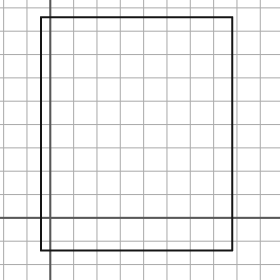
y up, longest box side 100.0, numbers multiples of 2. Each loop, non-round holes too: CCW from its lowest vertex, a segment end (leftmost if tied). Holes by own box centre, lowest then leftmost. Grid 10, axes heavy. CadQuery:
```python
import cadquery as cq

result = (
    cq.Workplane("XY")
    .moveTo(-4.0, -14.0)
    .lineTo(78.0, -14.0)
    .lineTo(78.0, 86.0)
    .lineTo(-4.0, 86.0)
    .close()
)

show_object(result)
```